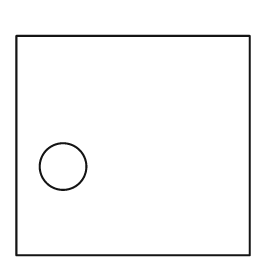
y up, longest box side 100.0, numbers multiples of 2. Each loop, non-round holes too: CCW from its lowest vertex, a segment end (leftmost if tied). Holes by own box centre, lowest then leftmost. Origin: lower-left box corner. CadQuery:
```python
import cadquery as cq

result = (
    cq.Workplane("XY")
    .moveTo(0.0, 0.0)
    .lineTo(100.0, 0.0)
    .lineTo(100.0, 94.0)
    .lineTo(0.0, 94.0)
    .close()
    .moveTo(20.0, 38.0)
    .circle(10.0)
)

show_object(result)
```